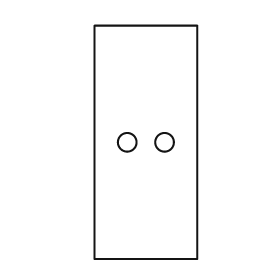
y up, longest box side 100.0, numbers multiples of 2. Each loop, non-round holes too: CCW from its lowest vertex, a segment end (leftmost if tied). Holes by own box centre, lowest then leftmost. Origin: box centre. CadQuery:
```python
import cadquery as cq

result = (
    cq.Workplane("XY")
    .moveTo(-22.0, -50.0)
    .lineTo(22.0, -50.0)
    .lineTo(22.0, 50.0)
    .lineTo(-22.0, 50.0)
    .close()
    .moveTo(-8.0, 0.0)
    .circle(4.0)
    .moveTo(8.0, 0.0)
    .circle(4.0)
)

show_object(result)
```